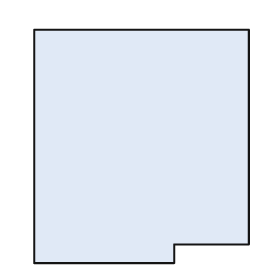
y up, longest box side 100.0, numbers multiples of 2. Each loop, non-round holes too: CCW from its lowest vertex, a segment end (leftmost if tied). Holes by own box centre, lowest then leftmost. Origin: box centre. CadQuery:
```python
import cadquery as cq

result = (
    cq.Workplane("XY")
    .moveTo(-46.0, -50.0)
    .lineTo(14.0, -50.0)
    .lineTo(14.0, -42.0)
    .lineTo(46.0, -42.0)
    .lineTo(46.0, 50.0)
    .lineTo(-46.0, 50.0)
    .close()
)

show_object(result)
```